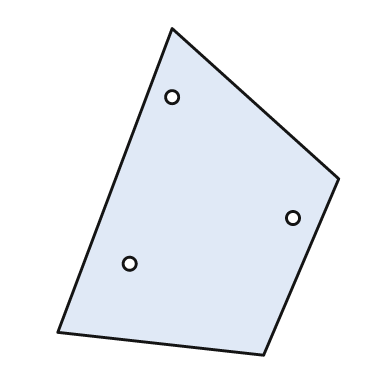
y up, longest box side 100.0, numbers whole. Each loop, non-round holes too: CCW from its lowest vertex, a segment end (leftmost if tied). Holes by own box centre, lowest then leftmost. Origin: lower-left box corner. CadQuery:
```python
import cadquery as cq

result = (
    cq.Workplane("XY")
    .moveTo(63.0, 0.0)
    .lineTo(86.0, 54.0)
    .lineTo(35.0, 100.0)
    .lineTo(0.0, 7.0)
    .close()
    .moveTo(22.0, 28.0)
    .circle(2.0)
    .moveTo(72.0, 42.0)
    .circle(2.0)
    .moveTo(35.0, 79.0)
    .circle(2.0)
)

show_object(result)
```